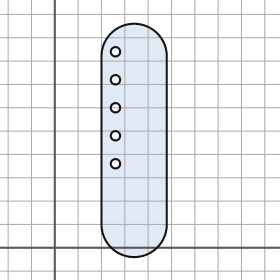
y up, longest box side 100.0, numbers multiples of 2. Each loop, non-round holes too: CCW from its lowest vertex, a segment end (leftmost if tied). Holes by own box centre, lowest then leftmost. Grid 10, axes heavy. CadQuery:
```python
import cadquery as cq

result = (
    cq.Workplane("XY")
    .moveTo(20.0, 10.0)
    .threePointArc((34.0, -4.0), (48.0, 10.0))
    .lineTo(48.0, 82.0)
    .threePointArc((34.0, 96.0), (20.0, 82.0))
    .close()
    .moveTo(26.0, 36.0)
    .circle(2.0)
    .moveTo(26.0, 48.0)
    .circle(2.0)
    .moveTo(26.0, 60.0)
    .circle(2.0)
    .moveTo(26.0, 72.0)
    .circle(2.0)
    .moveTo(26.0, 84.0)
    .circle(2.0)
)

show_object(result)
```